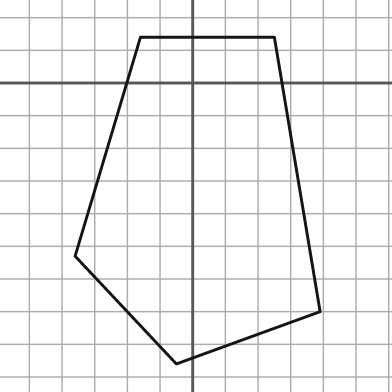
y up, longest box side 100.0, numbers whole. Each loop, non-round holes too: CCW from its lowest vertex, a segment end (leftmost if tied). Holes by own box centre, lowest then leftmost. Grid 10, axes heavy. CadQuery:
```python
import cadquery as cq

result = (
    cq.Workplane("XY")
    .moveTo(-5.0, -86.0)
    .lineTo(39.0, -70.0)
    .lineTo(25.0, 14.0)
    .lineTo(-16.0, 14.0)
    .lineTo(-36.0, -53.0)
    .close()
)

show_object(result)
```